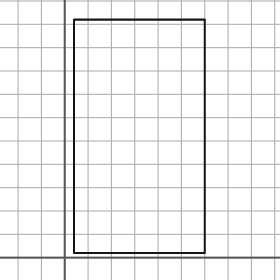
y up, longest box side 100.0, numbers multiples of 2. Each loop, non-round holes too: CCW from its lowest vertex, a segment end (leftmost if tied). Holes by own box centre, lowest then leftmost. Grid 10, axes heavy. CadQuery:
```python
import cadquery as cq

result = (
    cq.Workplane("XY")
    .moveTo(4.0, 2.0)
    .lineTo(60.0, 2.0)
    .lineTo(60.0, 102.0)
    .lineTo(4.0, 102.0)
    .close()
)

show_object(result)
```